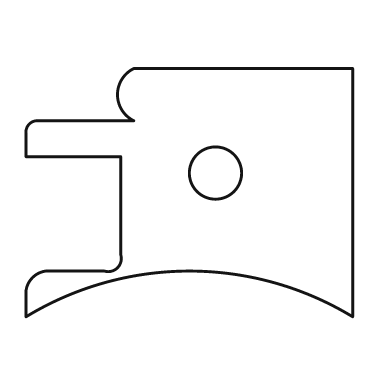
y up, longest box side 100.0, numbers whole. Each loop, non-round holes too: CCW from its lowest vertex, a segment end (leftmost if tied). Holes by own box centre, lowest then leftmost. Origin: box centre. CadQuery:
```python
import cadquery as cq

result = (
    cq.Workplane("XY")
    .moveTo(-50.0, -38.0)
    .threePointArc((0.0, -24.0), (50.0, -38.0))
    .lineTo(50.0, 38.0)
    .lineTo(-17.0, 38.0)
    .threePointArc((-22.0, 30.0), (-17.0, 22.0))
    .lineTo(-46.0, 22.0)
    .threePointArc((-49.0, 21.0), (-50.0, 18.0))
    .lineTo(-50.0, 11.0)
    .lineTo(-21.0, 11.0)
    .lineTo(-21.0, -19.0)
    .threePointArc((-22.0, -23.0), (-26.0, -24.0))
    .lineTo(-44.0, -24.0)
    .threePointArc((-48.0, -26.0), (-50.0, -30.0))
    .close()
    .moveTo(8.0, 6.0)
    .circle(8.0)
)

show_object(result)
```